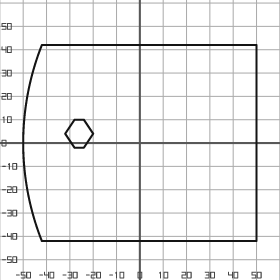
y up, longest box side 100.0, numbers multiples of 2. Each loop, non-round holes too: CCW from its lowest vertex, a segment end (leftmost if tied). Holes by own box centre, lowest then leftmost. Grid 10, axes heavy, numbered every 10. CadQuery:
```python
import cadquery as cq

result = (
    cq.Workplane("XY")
    .moveTo(-42.0, -42.0)
    .lineTo(50.0, -42.0)
    .lineTo(50.0, 42.0)
    .lineTo(-42.0, 42.0)
    .threePointArc((-50.0, 0.0), (-42.0, -42.0))
    .close()
    .moveTo(-28.0, -2.0)
    .lineTo(-24.0, -2.0)
    .lineTo(-20.0, 4.0)
    .lineTo(-24.0, 10.0)
    .lineTo(-28.0, 10.0)
    .lineTo(-32.0, 4.0)
    .close()
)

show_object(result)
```